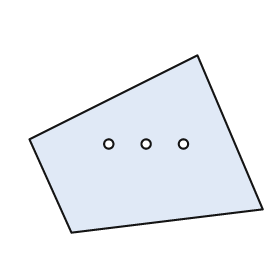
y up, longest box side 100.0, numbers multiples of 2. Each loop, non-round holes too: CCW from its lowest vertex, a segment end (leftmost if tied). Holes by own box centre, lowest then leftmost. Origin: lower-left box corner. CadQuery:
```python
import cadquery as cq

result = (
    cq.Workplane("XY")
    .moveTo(18.0, 0.0)
    .lineTo(100.0, 10.0)
    .lineTo(72.0, 76.0)
    .lineTo(0.0, 40.0)
    .close()
    .moveTo(34.0, 38.0)
    .circle(2.0)
    .moveTo(50.0, 38.0)
    .circle(2.0)
    .moveTo(66.0, 38.0)
    .circle(2.0)
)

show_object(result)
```